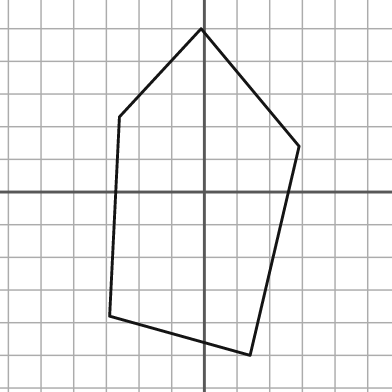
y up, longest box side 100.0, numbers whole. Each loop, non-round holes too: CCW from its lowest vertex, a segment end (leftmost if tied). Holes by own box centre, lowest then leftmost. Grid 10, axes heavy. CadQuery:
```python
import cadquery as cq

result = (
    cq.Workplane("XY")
    .moveTo(14.0, -50.0)
    .lineTo(29.0, 14.0)
    .lineTo(-1.0, 50.0)
    .lineTo(-26.0, 23.0)
    .lineTo(-29.0, -38.0)
    .close()
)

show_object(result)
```